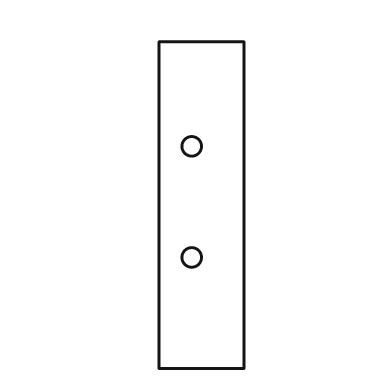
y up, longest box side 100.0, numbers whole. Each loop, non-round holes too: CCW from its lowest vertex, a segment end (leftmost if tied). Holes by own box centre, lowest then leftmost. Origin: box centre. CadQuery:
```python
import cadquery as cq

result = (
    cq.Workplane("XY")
    .moveTo(-13.0, -50.0)
    .lineTo(13.0, -50.0)
    .lineTo(13.0, 50.0)
    .lineTo(-13.0, 50.0)
    .close()
    .moveTo(-3.0, -16.0)
    .circle(3.0)
    .moveTo(-3.0, 18.0)
    .circle(3.0)
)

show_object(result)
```